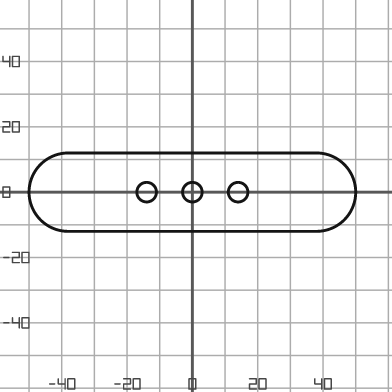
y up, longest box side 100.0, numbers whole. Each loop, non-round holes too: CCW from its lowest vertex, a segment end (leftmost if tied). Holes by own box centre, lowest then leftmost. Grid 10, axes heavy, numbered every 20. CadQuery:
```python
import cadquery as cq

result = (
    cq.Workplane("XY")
    .moveTo(-38.0, -12.0)
    .lineTo(38.0, -12.0)
    .threePointArc((50.0, 0.0), (38.0, 12.0))
    .lineTo(-38.0, 12.0)
    .threePointArc((-50.0, 0.0), (-38.0, -12.0))
    .close()
    .moveTo(-14.0, 0.0)
    .circle(3.0)
    .moveTo(0.0, 0.0)
    .circle(3.0)
    .moveTo(14.0, 0.0)
    .circle(3.0)
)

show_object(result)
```